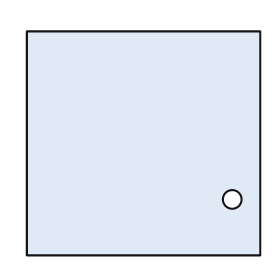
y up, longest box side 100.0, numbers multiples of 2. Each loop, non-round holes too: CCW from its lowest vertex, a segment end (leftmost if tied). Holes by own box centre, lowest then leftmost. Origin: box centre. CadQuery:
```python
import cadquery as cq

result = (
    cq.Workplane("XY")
    .moveTo(-50.0, -48.0)
    .lineTo(50.0, -48.0)
    .lineTo(50.0, 48.0)
    .lineTo(-50.0, 48.0)
    .close()
    .moveTo(38.0, -24.0)
    .circle(4.0)
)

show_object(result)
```